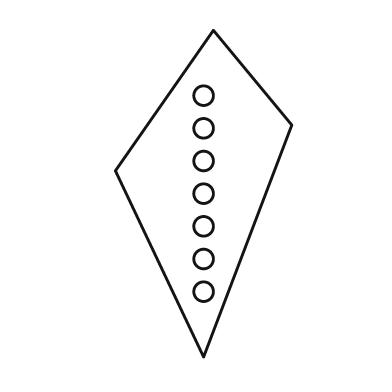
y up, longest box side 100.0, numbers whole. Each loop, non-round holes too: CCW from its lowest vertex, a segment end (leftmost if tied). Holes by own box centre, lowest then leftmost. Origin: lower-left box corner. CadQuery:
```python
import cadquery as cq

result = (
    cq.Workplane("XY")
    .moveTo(27.0, 0.0)
    .lineTo(54.0, 71.0)
    .lineTo(30.0, 100.0)
    .lineTo(0.0, 57.0)
    .close()
    .moveTo(27.0, 20.0)
    .circle(3.0)
    .moveTo(27.0, 30.0)
    .circle(3.0)
    .moveTo(27.0, 40.0)
    .circle(3.0)
    .moveTo(27.0, 50.0)
    .circle(3.0)
    .moveTo(27.0, 60.0)
    .circle(3.0)
    .moveTo(27.0, 70.0)
    .circle(3.0)
    .moveTo(27.0, 80.0)
    .circle(3.0)
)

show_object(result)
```